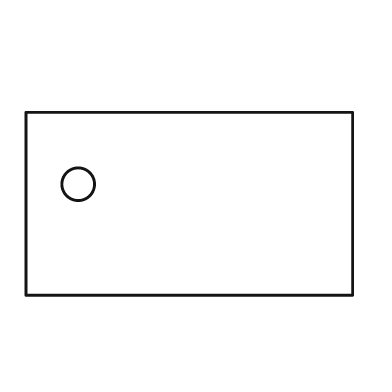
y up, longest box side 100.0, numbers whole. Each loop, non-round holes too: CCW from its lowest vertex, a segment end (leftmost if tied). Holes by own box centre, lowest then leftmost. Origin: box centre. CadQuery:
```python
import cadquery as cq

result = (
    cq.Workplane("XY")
    .moveTo(-50.0, -28.0)
    .lineTo(50.0, -28.0)
    .lineTo(50.0, 28.0)
    .lineTo(-50.0, 28.0)
    .close()
    .moveTo(-34.0, 6.0)
    .circle(5.0)
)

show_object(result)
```